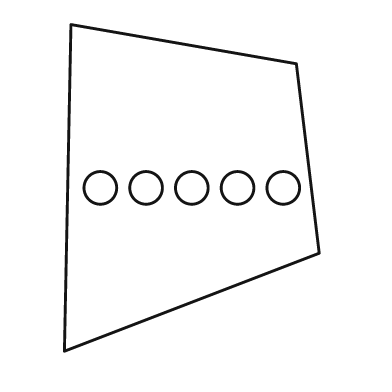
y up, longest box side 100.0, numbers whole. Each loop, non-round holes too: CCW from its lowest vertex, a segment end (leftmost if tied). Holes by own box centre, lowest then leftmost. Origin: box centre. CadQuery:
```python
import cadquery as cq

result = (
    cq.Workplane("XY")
    .moveTo(-39.0, -50.0)
    .lineTo(39.0, -20.0)
    .lineTo(32.0, 38.0)
    .lineTo(-37.0, 50.0)
    .close()
    .moveTo(-28.0, 0.0)
    .circle(5.0)
    .moveTo(-14.0, 0.0)
    .circle(5.0)
    .moveTo(0.0, 0.0)
    .circle(5.0)
    .moveTo(14.0, 0.0)
    .circle(5.0)
    .moveTo(28.0, 0.0)
    .circle(5.0)
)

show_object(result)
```